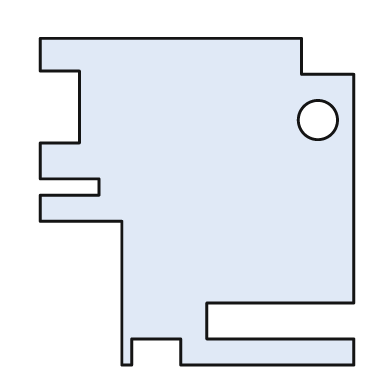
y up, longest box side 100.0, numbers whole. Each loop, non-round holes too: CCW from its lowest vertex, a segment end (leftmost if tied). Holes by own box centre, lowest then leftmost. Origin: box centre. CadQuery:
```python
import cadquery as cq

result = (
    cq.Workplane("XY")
    .moveTo(-23.0, -50.0)
    .lineTo(-20.0, -50.0)
    .lineTo(-20.0, -42.0)
    .lineTo(-5.0, -42.0)
    .lineTo(-5.0, -50.0)
    .lineTo(48.0, -50.0)
    .lineTo(48.0, -42.0)
    .lineTo(3.0, -42.0)
    .lineTo(3.0, -31.0)
    .lineTo(48.0, -31.0)
    .lineTo(48.0, 39.0)
    .lineTo(32.0, 39.0)
    .lineTo(32.0, 50.0)
    .lineTo(-48.0, 50.0)
    .lineTo(-48.0, 40.0)
    .lineTo(-36.0, 40.0)
    .lineTo(-36.0, 18.0)
    .lineTo(-48.0, 18.0)
    .lineTo(-48.0, 7.0)
    .lineTo(-30.0, 7.0)
    .lineTo(-30.0, 2.0)
    .lineTo(-48.0, 2.0)
    .lineTo(-48.0, -6.0)
    .lineTo(-23.0, -6.0)
    .close()
    .moveTo(37.0, 25.0)
    .circle(6.0)
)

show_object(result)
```